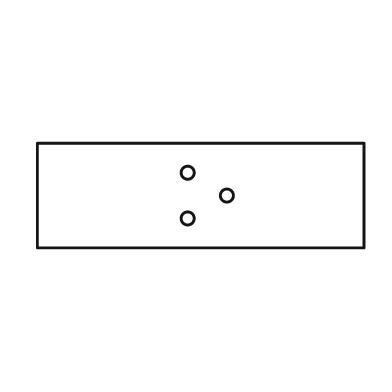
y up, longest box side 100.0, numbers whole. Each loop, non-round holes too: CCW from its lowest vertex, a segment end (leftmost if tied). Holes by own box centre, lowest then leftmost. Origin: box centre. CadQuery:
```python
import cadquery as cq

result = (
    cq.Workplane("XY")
    .moveTo(-50.0, -16.0)
    .lineTo(50.0, -16.0)
    .lineTo(50.0, 16.0)
    .lineTo(-50.0, 16.0)
    .close()
    .moveTo(-4.0, -7.0)
    .circle(2.0)
    .moveTo(8.0, 0.0)
    .circle(2.0)
    .moveTo(-4.0, 7.0)
    .circle(2.0)
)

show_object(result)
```